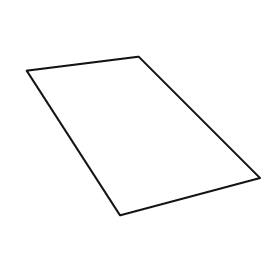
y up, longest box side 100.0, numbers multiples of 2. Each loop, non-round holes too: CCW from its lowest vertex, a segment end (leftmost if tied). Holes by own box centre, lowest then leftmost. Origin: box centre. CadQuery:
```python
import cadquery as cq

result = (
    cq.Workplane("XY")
    .moveTo(-10.0, -34.0)
    .lineTo(50.0, -18.0)
    .lineTo(-2.0, 34.0)
    .lineTo(-50.0, 28.0)
    .close()
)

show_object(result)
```